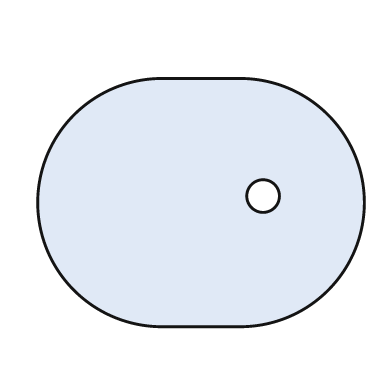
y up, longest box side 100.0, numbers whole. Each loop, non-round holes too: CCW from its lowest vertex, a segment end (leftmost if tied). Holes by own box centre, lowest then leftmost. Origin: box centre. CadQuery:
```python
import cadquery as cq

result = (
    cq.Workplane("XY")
    .moveTo(-12.0, -38.0)
    .lineTo(12.0, -38.0)
    .threePointArc((50.0, 0.0), (12.0, 38.0))
    .lineTo(-12.0, 38.0)
    .threePointArc((-50.0, 0.0), (-12.0, -38.0))
    .close()
    .moveTo(19.0, 2.0)
    .circle(5.0)
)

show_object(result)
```